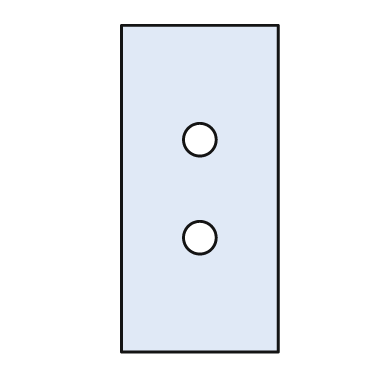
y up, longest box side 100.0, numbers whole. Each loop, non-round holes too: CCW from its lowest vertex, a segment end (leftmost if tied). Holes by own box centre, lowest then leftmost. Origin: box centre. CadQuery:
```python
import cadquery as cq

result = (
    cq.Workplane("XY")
    .moveTo(-24.0, -50.0)
    .lineTo(24.0, -50.0)
    .lineTo(24.0, 50.0)
    .lineTo(-24.0, 50.0)
    .close()
    .moveTo(0.0, -15.0)
    .circle(5.0)
    .moveTo(0.0, 15.0)
    .circle(5.0)
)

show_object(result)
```